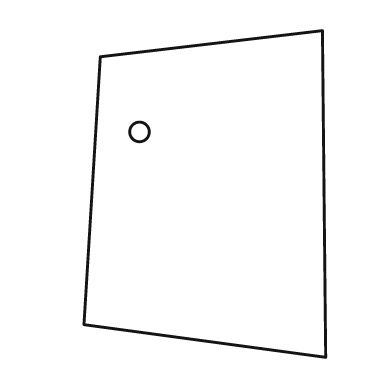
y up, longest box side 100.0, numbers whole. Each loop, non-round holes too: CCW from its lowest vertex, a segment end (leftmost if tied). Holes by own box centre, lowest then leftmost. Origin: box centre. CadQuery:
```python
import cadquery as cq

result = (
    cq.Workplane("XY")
    .moveTo(37.0, -50.0)
    .lineTo(36.0, 50.0)
    .lineTo(-32.0, 42.0)
    .lineTo(-37.0, -40.0)
    .close()
    .moveTo(-20.0, 19.0)
    .circle(3.0)
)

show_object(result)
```